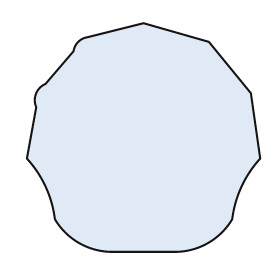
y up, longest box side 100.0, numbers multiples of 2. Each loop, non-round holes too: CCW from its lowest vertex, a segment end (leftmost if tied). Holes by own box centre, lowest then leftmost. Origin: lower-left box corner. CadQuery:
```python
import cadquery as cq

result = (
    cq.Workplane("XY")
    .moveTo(36.0, 0.0)
    .lineTo(64.0, 0.0)
    .threePointArc((78.0, 4.0), (88.0, 14.0))
    .threePointArc((92.0, 28.0), (100.0, 40.0))
    .lineTo(96.0, 68.0)
    .lineTo(78.0, 90.0)
    .lineTo(50.0, 98.0)
    .lineTo(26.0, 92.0)
    .threePointArc((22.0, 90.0), (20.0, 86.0))
    .lineTo(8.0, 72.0)
    .threePointArc((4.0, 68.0), (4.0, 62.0))
    .lineTo(0.0, 40.0)
    .threePointArc((8.0, 28.0), (12.0, 14.0))
    .threePointArc((22.0, 4.0), (36.0, 0.0))
    .close()
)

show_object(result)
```